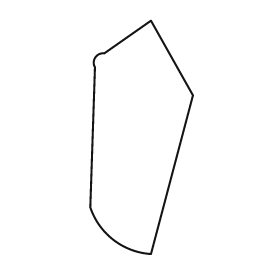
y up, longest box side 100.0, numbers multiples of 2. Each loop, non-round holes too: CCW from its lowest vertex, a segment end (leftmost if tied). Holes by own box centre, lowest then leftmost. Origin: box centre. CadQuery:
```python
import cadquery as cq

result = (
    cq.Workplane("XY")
    .moveTo(4.0, -50.0)
    .lineTo(22.0, 18.0)
    .lineTo(4.0, 50.0)
    .lineTo(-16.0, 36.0)
    .threePointArc((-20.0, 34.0), (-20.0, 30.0))
    .lineTo(-22.0, -30.0)
    .threePointArc((-12.0, -44.0), (4.0, -50.0))
    .close()
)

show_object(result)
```